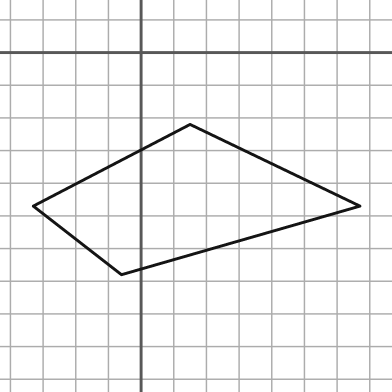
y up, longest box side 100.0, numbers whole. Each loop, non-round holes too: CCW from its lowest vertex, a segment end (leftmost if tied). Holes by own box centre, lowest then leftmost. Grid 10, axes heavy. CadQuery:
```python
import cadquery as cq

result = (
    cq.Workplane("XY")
    .moveTo(-6.0, -68.0)
    .lineTo(67.0, -47.0)
    .lineTo(15.0, -22.0)
    .lineTo(-33.0, -47.0)
    .close()
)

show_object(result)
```